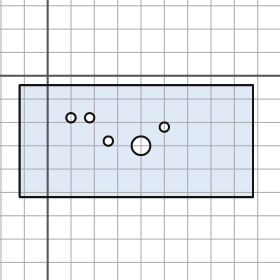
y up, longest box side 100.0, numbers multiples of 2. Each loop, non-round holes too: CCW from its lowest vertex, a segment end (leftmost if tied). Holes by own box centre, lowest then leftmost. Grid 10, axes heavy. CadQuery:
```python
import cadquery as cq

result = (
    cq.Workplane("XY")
    .moveTo(-12.0, -52.0)
    .lineTo(88.0, -52.0)
    .lineTo(88.0, -4.0)
    .lineTo(-12.0, -4.0)
    .close()
    .moveTo(40.0, -30.0)
    .circle(4.0)
    .moveTo(26.0, -28.0)
    .circle(2.0)
    .moveTo(50.0, -22.0)
    .circle(2.0)
    .moveTo(10.0, -18.0)
    .circle(2.0)
    .moveTo(18.0, -18.0)
    .circle(2.0)
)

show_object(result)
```